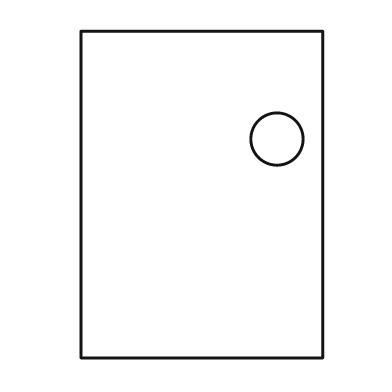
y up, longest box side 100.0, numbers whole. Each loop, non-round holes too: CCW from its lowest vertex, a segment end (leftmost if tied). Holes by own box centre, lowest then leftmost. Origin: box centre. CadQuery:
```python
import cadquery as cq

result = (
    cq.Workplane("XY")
    .moveTo(-37.0, -50.0)
    .lineTo(37.0, -50.0)
    .lineTo(37.0, 50.0)
    .lineTo(-37.0, 50.0)
    .close()
    .moveTo(23.0, 17.0)
    .circle(8.0)
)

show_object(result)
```